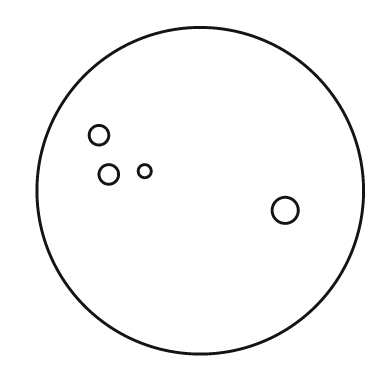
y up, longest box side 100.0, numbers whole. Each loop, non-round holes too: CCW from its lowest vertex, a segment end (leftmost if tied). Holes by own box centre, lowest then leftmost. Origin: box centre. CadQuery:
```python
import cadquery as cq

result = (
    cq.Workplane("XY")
    .moveTo(0.0, 0.0)
    .circle(50.0)
    .moveTo(26.0, -6.0)
    .circle(4.0)
    .moveTo(-28.0, 5.0)
    .circle(3.0)
    .moveTo(-17.0, 6.0)
    .circle(2.0)
    .moveTo(-31.0, 17.0)
    .circle(3.0)
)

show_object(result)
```